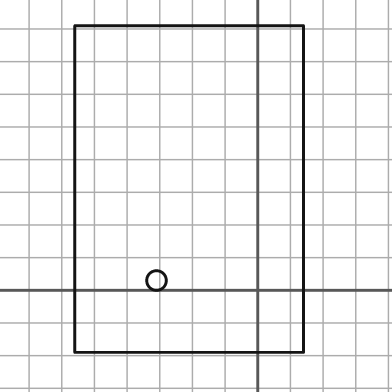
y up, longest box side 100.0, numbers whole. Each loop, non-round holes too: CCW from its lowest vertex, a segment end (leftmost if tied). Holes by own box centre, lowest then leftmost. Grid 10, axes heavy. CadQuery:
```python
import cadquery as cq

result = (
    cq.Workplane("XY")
    .moveTo(-56.0, -19.0)
    .lineTo(14.0, -19.0)
    .lineTo(14.0, 81.0)
    .lineTo(-56.0, 81.0)
    .close()
    .moveTo(-31.0, 3.0)
    .circle(3.0)
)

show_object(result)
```